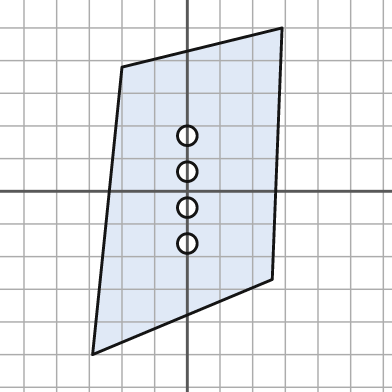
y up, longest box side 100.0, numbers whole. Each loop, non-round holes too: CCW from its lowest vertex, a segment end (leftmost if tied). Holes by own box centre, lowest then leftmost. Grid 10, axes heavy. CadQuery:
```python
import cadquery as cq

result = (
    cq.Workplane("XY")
    .moveTo(-29.0, -50.0)
    .lineTo(26.0, -27.0)
    .lineTo(29.0, 50.0)
    .lineTo(-20.0, 38.0)
    .close()
    .moveTo(0.0, -16.0)
    .circle(3.0)
    .moveTo(0.0, -5.0)
    .circle(3.0)
    .moveTo(0.0, 6.0)
    .circle(3.0)
    .moveTo(0.0, 17.0)
    .circle(3.0)
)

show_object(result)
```